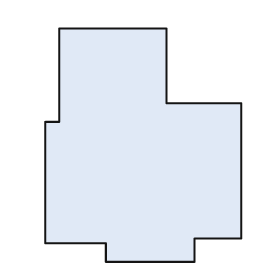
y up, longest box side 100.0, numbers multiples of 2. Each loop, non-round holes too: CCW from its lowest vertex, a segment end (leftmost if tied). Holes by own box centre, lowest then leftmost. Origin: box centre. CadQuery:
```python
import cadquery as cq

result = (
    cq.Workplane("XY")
    .moveTo(-16.0, -50.0)
    .lineTo(22.0, -50.0)
    .lineTo(22.0, -40.0)
    .lineTo(42.0, -40.0)
    .lineTo(42.0, 18.0)
    .lineTo(10.0, 18.0)
    .lineTo(10.0, 50.0)
    .lineTo(-36.0, 50.0)
    .lineTo(-36.0, 10.0)
    .lineTo(-42.0, 10.0)
    .lineTo(-42.0, -42.0)
    .lineTo(-16.0, -42.0)
    .close()
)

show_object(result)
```